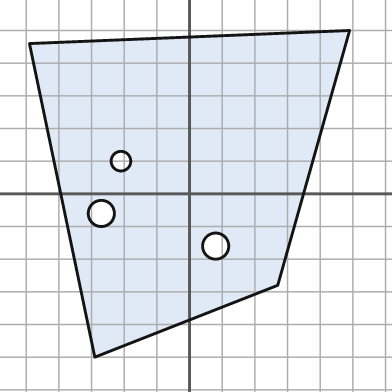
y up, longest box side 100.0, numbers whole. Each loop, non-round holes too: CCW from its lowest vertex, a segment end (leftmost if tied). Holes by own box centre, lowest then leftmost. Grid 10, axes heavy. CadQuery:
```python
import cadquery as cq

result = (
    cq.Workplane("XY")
    .moveTo(-29.0, -50.0)
    .lineTo(27.0, -28.0)
    .lineTo(49.0, 50.0)
    .lineTo(-49.0, 46.0)
    .close()
    .moveTo(8.0, -16.0)
    .circle(4.0)
    .moveTo(-27.0, -6.0)
    .circle(4.0)
    .moveTo(-21.0, 10.0)
    .circle(3.0)
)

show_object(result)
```